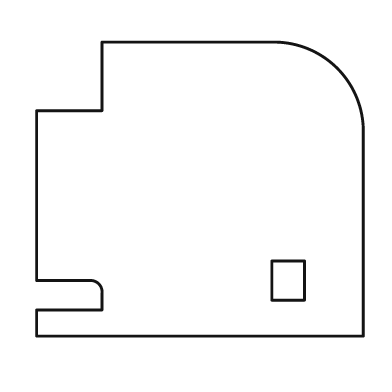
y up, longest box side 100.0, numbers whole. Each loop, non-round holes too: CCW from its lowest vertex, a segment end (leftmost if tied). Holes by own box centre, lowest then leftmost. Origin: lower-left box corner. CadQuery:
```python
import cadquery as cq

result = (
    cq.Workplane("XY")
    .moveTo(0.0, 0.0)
    .lineTo(100.0, 0.0)
    .lineTo(100.0, 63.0)
    .threePointArc((92.0, 82.0), (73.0, 90.0))
    .lineTo(20.0, 90.0)
    .lineTo(20.0, 69.0)
    .lineTo(0.0, 69.0)
    .lineTo(0.0, 17.0)
    .lineTo(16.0, 17.0)
    .threePointArc((19.0, 16.0), (20.0, 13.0))
    .lineTo(20.0, 8.0)
    .lineTo(0.0, 8.0)
    .close()
    .moveTo(72.0, 11.0)
    .lineTo(82.0, 11.0)
    .lineTo(82.0, 23.0)
    .lineTo(72.0, 23.0)
    .close()
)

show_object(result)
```